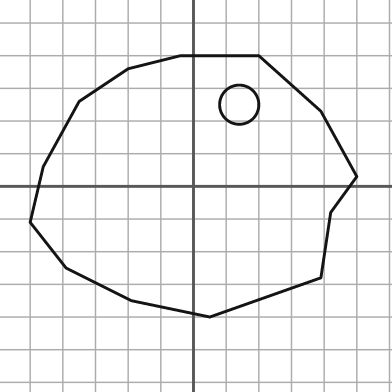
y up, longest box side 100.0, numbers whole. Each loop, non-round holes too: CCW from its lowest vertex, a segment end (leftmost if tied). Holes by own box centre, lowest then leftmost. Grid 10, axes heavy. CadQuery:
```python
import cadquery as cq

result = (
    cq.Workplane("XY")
    .moveTo(5.0, -40.0)
    .lineTo(39.0, -28.0)
    .lineTo(42.0, -8.0)
    .lineTo(50.0, 3.0)
    .lineTo(39.0, 23.0)
    .lineTo(20.0, 40.0)
    .lineTo(-4.0, 40.0)
    .lineTo(-20.0, 36.0)
    .lineTo(-35.0, 26.0)
    .lineTo(-46.0, 6.0)
    .lineTo(-50.0, -11.0)
    .lineTo(-39.0, -25.0)
    .lineTo(-19.0, -35.0)
    .close()
    .moveTo(14.0, 25.0)
    .circle(6.0)
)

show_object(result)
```